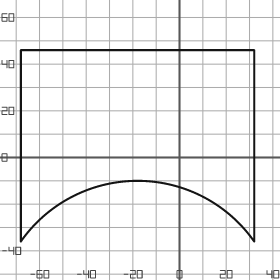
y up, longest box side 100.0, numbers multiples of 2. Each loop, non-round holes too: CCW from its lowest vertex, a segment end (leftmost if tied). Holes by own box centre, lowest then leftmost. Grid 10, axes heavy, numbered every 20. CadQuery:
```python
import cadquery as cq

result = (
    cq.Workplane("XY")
    .moveTo(-68.0, -36.0)
    .threePointArc((-18.0, -10.0), (32.0, -36.0))
    .lineTo(32.0, 46.0)
    .lineTo(-68.0, 46.0)
    .close()
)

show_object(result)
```